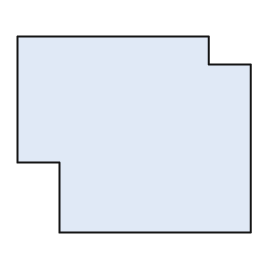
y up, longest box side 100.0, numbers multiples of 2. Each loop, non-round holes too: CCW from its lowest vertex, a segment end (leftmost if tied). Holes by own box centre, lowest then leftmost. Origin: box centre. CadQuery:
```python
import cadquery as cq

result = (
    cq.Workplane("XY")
    .moveTo(-32.0, -42.0)
    .lineTo(50.0, -42.0)
    .lineTo(50.0, 30.0)
    .lineTo(32.0, 30.0)
    .lineTo(32.0, 42.0)
    .lineTo(-50.0, 42.0)
    .lineTo(-50.0, -12.0)
    .lineTo(-32.0, -12.0)
    .close()
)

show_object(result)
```